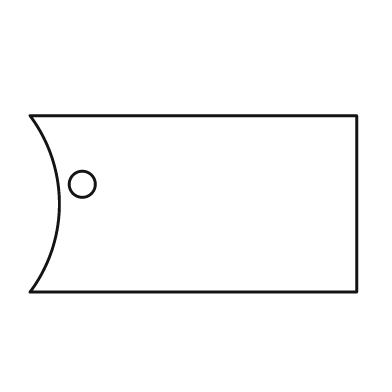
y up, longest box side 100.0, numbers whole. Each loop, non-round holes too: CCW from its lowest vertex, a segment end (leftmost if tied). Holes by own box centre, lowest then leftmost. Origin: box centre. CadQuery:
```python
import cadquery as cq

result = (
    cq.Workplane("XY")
    .moveTo(-50.0, -27.0)
    .lineTo(50.0, -27.0)
    .lineTo(50.0, 27.0)
    .lineTo(-50.0, 27.0)
    .threePointArc((-41.0, 0.0), (-50.0, -27.0))
    .close()
    .moveTo(-34.0, 6.0)
    .circle(4.0)
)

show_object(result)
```